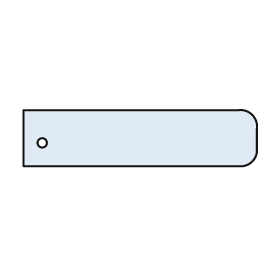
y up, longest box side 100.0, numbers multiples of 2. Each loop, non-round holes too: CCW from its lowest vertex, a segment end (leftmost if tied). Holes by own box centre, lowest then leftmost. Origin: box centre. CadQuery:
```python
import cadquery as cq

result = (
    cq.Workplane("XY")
    .moveTo(-50.0, -12.0)
    .lineTo(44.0, -12.0)
    .threePointArc((48.0, -10.0), (50.0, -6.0))
    .lineTo(50.0, 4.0)
    .threePointArc((48.0, 10.0), (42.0, 12.0))
    .lineTo(-50.0, 12.0)
    .close()
    .moveTo(-42.0, -2.0)
    .circle(2.0)
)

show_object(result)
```